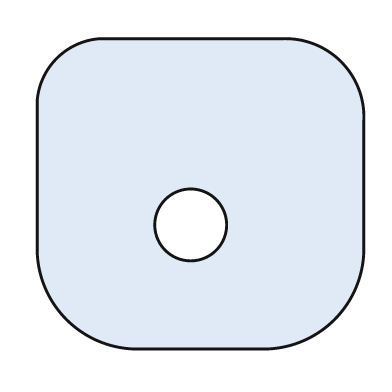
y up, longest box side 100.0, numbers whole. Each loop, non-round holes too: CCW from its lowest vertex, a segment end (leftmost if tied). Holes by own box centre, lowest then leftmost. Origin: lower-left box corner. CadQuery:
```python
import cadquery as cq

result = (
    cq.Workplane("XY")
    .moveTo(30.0, 0.0)
    .lineTo(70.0, 0.0)
    .threePointArc((91.0, 9.0), (100.0, 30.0))
    .lineTo(100.0, 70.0)
    .threePointArc((93.0, 88.0), (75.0, 95.0))
    .lineTo(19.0, 95.0)
    .threePointArc((6.0, 89.0), (0.0, 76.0))
    .lineTo(0.0, 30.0)
    .threePointArc((9.0, 9.0), (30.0, 0.0))
    .close()
    .moveTo(47.0, 38.0)
    .circle(11.0)
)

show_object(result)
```